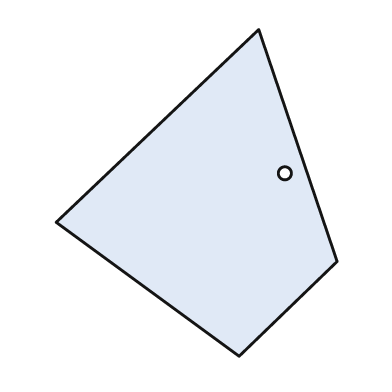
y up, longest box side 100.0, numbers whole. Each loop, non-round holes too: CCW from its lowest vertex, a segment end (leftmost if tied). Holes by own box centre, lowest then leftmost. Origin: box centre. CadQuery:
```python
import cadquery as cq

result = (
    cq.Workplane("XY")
    .moveTo(13.0, -50.0)
    .lineTo(43.0, -21.0)
    .lineTo(19.0, 50.0)
    .lineTo(-43.0, -9.0)
    .close()
    .moveTo(27.0, 6.0)
    .circle(2.0)
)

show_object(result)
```